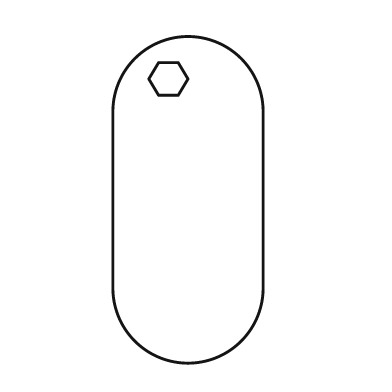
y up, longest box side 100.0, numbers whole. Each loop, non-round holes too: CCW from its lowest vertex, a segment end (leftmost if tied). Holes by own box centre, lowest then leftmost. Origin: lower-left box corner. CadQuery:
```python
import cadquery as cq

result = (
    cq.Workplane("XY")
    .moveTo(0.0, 23.0)
    .threePointArc((23.0, 0.0), (46.0, 23.0))
    .lineTo(46.0, 77.0)
    .threePointArc((23.0, 100.0), (0.0, 77.0))
    .close()
    .moveTo(14.0, 82.0)
    .lineTo(20.0, 82.0)
    .lineTo(23.0, 87.0)
    .lineTo(20.0, 92.0)
    .lineTo(14.0, 92.0)
    .lineTo(11.0, 87.0)
    .close()
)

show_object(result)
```